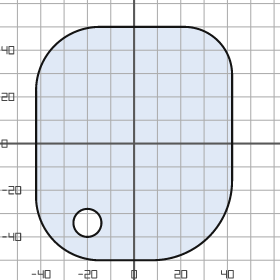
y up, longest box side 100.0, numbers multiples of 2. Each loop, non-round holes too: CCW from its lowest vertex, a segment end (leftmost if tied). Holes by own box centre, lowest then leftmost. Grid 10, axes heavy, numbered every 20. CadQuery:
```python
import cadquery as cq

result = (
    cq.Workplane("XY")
    .moveTo(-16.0, -50.0)
    .lineTo(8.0, -50.0)
    .threePointArc((32.0, -40.0), (42.0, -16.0))
    .lineTo(42.0, 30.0)
    .threePointArc((36.0, 44.0), (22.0, 50.0))
    .lineTo(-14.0, 50.0)
    .threePointArc((-34.0, 42.0), (-42.0, 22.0))
    .lineTo(-42.0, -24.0)
    .threePointArc((-34.0, -42.0), (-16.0, -50.0))
    .close()
    .moveTo(-20.0, -34.0)
    .circle(6.0)
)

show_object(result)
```